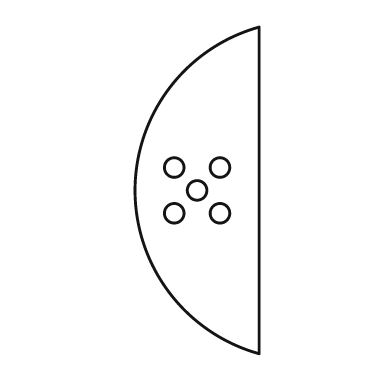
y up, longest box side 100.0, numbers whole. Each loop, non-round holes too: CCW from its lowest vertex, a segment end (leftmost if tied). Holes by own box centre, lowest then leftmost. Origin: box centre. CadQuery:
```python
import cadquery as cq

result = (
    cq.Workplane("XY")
    .moveTo(19.0, -50.0)
    .lineTo(19.0, 50.0)
    .threePointArc((-19.0, 0.0), (19.0, -50.0))
    .close()
    .moveTo(-7.0, -7.0)
    .circle(3.0)
    .moveTo(7.0, -7.0)
    .circle(3.0)
    .moveTo(0.0, 0.0)
    .circle(3.0)
    .moveTo(-7.0, 7.0)
    .circle(3.0)
    .moveTo(7.0, 7.0)
    .circle(3.0)
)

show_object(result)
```